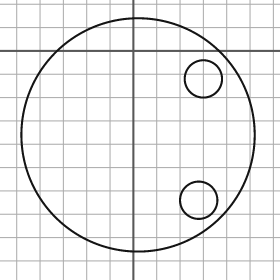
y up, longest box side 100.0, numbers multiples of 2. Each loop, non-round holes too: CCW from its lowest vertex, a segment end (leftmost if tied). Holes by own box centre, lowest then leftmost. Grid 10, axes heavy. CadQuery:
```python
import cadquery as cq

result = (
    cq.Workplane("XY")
    .moveTo(2.0, -36.0)
    .circle(50.0)
    .moveTo(28.0, -64.0)
    .circle(8.0)
    .moveTo(30.0, -12.0)
    .circle(8.0)
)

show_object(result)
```